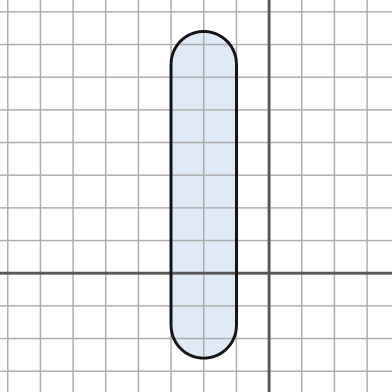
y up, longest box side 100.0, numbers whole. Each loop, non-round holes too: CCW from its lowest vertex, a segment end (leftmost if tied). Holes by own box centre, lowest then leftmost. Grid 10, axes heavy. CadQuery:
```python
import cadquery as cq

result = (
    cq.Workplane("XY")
    .moveTo(-30.0, -16.0)
    .threePointArc((-20.0, -26.0), (-10.0, -16.0))
    .lineTo(-10.0, 64.0)
    .threePointArc((-20.0, 74.0), (-30.0, 64.0))
    .close()
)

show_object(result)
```